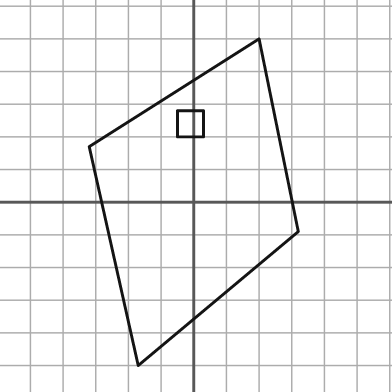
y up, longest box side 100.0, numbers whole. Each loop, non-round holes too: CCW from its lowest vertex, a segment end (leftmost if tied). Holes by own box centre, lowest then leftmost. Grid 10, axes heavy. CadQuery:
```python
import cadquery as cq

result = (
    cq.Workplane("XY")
    .moveTo(-17.0, -50.0)
    .lineTo(32.0, -9.0)
    .lineTo(20.0, 50.0)
    .lineTo(-32.0, 17.0)
    .close()
    .moveTo(-5.0, 20.0)
    .lineTo(3.0, 20.0)
    .lineTo(3.0, 28.0)
    .lineTo(-5.0, 28.0)
    .close()
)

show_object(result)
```